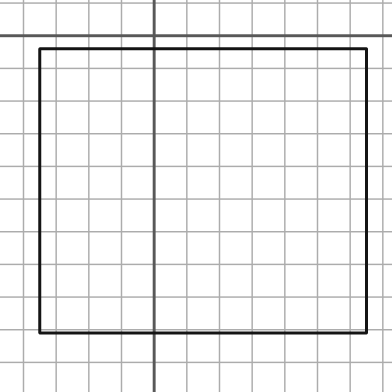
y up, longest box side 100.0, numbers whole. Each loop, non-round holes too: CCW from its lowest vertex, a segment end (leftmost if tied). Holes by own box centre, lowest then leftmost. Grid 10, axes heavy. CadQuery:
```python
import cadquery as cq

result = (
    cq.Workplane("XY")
    .moveTo(-35.0, -91.0)
    .lineTo(65.0, -91.0)
    .lineTo(65.0, -4.0)
    .lineTo(-35.0, -4.0)
    .close()
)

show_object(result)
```